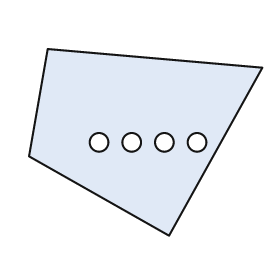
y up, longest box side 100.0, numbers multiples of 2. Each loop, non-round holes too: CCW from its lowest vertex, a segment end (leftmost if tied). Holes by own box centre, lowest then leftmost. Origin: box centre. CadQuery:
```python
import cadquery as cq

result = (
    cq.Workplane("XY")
    .moveTo(10.0, -40.0)
    .lineTo(50.0, 32.0)
    .lineTo(-42.0, 40.0)
    .lineTo(-50.0, -6.0)
    .close()
    .moveTo(-20.0, 0.0)
    .circle(4.0)
    .moveTo(-6.0, 0.0)
    .circle(4.0)
    .moveTo(8.0, 0.0)
    .circle(4.0)
    .moveTo(22.0, 0.0)
    .circle(4.0)
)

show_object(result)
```